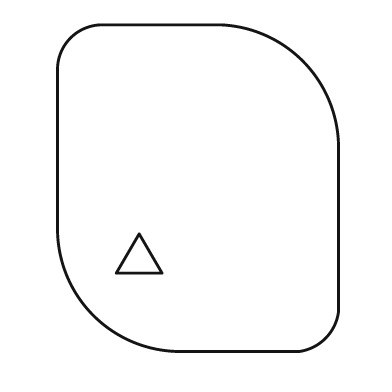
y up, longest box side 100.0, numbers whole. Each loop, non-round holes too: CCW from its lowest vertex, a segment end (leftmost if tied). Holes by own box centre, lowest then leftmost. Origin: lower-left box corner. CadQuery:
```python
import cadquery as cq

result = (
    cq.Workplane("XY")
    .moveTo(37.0, 0.0)
    .lineTo(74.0, 0.0)
    .threePointArc((82.0, 4.0), (86.0, 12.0))
    .lineTo(86.0, 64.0)
    .threePointArc((75.0, 89.0), (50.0, 100.0))
    .lineTo(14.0, 100.0)
    .threePointArc((4.0, 96.0), (0.0, 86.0))
    .lineTo(0.0, 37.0)
    .threePointArc((11.0, 11.0), (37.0, 0.0))
    .close()
    .moveTo(18.0, 24.0)
    .lineTo(32.0, 24.0)
    .lineTo(25.0, 36.0)
    .close()
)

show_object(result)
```